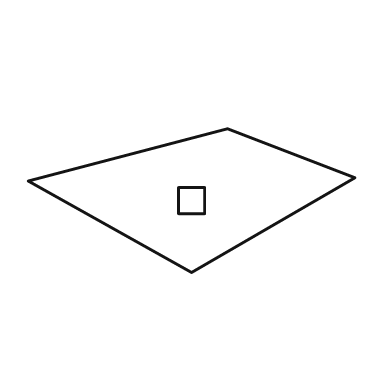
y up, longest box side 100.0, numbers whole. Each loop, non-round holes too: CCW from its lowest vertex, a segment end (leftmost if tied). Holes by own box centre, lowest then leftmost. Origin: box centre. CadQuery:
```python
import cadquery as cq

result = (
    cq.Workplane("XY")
    .moveTo(0.0, -22.0)
    .lineTo(50.0, 7.0)
    .lineTo(11.0, 22.0)
    .lineTo(-50.0, 6.0)
    .close()
    .moveTo(-4.0, -4.0)
    .lineTo(4.0, -4.0)
    .lineTo(4.0, 4.0)
    .lineTo(-4.0, 4.0)
    .close()
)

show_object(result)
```